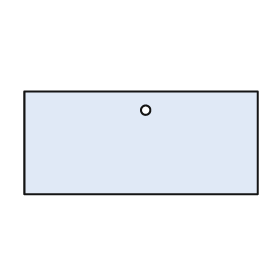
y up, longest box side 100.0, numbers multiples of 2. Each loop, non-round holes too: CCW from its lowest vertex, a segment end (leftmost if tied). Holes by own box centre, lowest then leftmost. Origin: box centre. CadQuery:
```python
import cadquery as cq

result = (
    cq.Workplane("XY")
    .moveTo(-50.0, -22.0)
    .lineTo(50.0, -22.0)
    .lineTo(50.0, 22.0)
    .lineTo(-50.0, 22.0)
    .close()
    .moveTo(2.0, 14.0)
    .circle(2.0)
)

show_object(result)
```